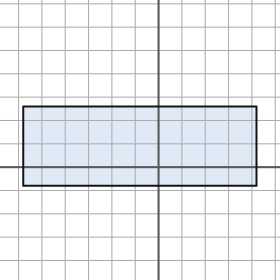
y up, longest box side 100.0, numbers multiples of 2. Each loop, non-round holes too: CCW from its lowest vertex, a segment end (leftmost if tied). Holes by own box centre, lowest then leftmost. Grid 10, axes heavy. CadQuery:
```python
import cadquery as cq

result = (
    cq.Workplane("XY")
    .moveTo(-58.0, -8.0)
    .lineTo(42.0, -8.0)
    .lineTo(42.0, 26.0)
    .lineTo(-58.0, 26.0)
    .close()
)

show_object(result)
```